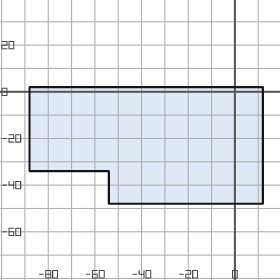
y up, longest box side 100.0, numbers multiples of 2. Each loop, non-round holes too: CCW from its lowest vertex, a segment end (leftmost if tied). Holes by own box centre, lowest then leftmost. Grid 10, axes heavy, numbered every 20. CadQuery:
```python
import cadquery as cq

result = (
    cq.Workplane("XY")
    .moveTo(-54.0, -48.0)
    .lineTo(12.0, -48.0)
    .lineTo(12.0, 2.0)
    .lineTo(-88.0, 2.0)
    .lineTo(-88.0, -34.0)
    .lineTo(-54.0, -34.0)
    .close()
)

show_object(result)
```